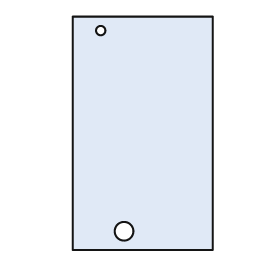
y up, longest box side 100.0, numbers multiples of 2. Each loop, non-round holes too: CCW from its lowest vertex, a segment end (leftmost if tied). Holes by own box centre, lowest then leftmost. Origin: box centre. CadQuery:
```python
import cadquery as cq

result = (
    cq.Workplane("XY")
    .moveTo(-30.0, -50.0)
    .lineTo(30.0, -50.0)
    .lineTo(30.0, 50.0)
    .lineTo(-30.0, 50.0)
    .close()
    .moveTo(-8.0, -42.0)
    .circle(4.0)
    .moveTo(-18.0, 44.0)
    .circle(2.0)
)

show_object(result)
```